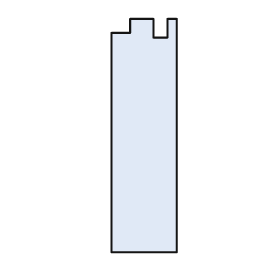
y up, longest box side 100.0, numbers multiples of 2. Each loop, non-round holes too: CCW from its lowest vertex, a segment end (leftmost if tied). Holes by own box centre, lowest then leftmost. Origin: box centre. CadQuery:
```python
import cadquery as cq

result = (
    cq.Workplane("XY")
    .moveTo(-14.0, -50.0)
    .lineTo(14.0, -50.0)
    .lineTo(14.0, 50.0)
    .lineTo(10.0, 50.0)
    .lineTo(10.0, 42.0)
    .lineTo(4.0, 42.0)
    .lineTo(4.0, 50.0)
    .lineTo(-6.0, 50.0)
    .lineTo(-6.0, 44.0)
    .lineTo(-14.0, 44.0)
    .close()
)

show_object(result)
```